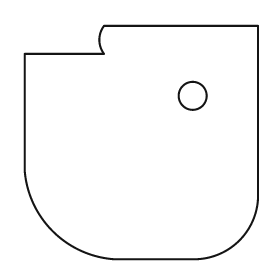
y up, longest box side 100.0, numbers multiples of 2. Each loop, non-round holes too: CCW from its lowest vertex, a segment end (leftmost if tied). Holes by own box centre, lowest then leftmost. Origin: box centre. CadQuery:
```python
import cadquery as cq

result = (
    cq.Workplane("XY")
    .moveTo(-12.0, -50.0)
    .lineTo(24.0, -50.0)
    .threePointArc((42.0, -42.0), (50.0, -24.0))
    .lineTo(50.0, 50.0)
    .lineTo(-16.0, 50.0)
    .threePointArc((-18.0, 44.0), (-16.0, 38.0))
    .lineTo(-50.0, 38.0)
    .lineTo(-50.0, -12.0)
    .threePointArc((-38.0, -38.0), (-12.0, -50.0))
    .close()
    .moveTo(22.0, 20.0)
    .circle(6.0)
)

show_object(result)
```